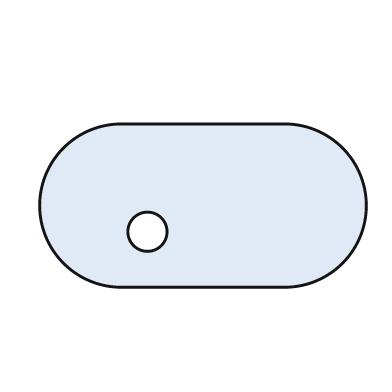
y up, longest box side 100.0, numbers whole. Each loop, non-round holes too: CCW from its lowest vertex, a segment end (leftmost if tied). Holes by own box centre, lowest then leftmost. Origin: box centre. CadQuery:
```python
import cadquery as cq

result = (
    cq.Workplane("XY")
    .moveTo(-25.0, -25.0)
    .lineTo(25.0, -25.0)
    .threePointArc((50.0, 0.0), (25.0, 25.0))
    .lineTo(-25.0, 25.0)
    .threePointArc((-50.0, 0.0), (-25.0, -25.0))
    .close()
    .moveTo(-17.0, -8.0)
    .circle(6.0)
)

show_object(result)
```